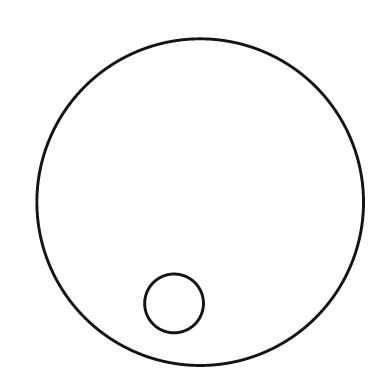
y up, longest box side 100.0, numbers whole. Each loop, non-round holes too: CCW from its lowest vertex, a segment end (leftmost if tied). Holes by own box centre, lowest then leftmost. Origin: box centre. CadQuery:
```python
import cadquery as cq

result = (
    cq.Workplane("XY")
    .moveTo(0.0, 0.0)
    .circle(50.0)
    .moveTo(-8.0, -31.0)
    .circle(9.0)
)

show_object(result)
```